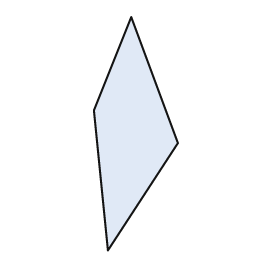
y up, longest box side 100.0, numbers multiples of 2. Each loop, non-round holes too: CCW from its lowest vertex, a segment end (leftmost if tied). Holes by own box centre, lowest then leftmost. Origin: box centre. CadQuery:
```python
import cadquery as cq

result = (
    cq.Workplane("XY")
    .moveTo(-12.0, -50.0)
    .lineTo(18.0, -4.0)
    .lineTo(-2.0, 50.0)
    .lineTo(-18.0, 10.0)
    .close()
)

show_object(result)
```